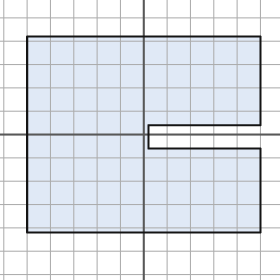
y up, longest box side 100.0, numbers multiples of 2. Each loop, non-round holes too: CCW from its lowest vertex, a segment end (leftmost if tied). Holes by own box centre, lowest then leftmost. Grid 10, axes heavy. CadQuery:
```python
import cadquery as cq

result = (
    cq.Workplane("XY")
    .moveTo(-50.0, -42.0)
    .lineTo(50.0, -42.0)
    .lineTo(50.0, -6.0)
    .lineTo(2.0, -6.0)
    .lineTo(2.0, 4.0)
    .lineTo(50.0, 4.0)
    .lineTo(50.0, 42.0)
    .lineTo(-50.0, 42.0)
    .close()
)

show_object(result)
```